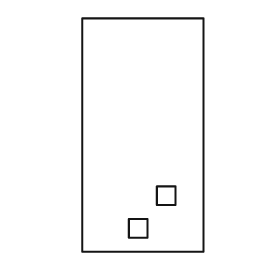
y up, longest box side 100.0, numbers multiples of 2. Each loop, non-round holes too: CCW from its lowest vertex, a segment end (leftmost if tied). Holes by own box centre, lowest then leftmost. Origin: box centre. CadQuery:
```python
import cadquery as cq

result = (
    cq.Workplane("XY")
    .moveTo(-26.0, -50.0)
    .lineTo(26.0, -50.0)
    .lineTo(26.0, 50.0)
    .lineTo(-26.0, 50.0)
    .close()
    .moveTo(-6.0, -44.0)
    .lineTo(2.0, -44.0)
    .lineTo(2.0, -36.0)
    .lineTo(-6.0, -36.0)
    .close()
    .moveTo(6.0, -30.0)
    .lineTo(14.0, -30.0)
    .lineTo(14.0, -22.0)
    .lineTo(6.0, -22.0)
    .close()
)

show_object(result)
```